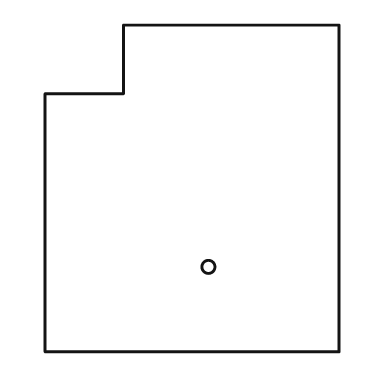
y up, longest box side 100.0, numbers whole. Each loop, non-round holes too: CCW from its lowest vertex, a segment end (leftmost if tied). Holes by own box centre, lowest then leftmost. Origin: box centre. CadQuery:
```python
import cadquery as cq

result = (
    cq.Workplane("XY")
    .moveTo(-45.0, -50.0)
    .lineTo(45.0, -50.0)
    .lineTo(45.0, 50.0)
    .lineTo(-21.0, 50.0)
    .lineTo(-21.0, 29.0)
    .lineTo(-45.0, 29.0)
    .close()
    .moveTo(5.0, -24.0)
    .circle(2.0)
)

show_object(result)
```